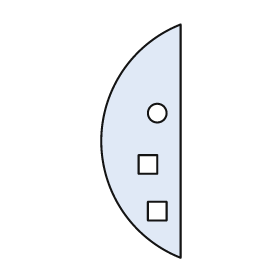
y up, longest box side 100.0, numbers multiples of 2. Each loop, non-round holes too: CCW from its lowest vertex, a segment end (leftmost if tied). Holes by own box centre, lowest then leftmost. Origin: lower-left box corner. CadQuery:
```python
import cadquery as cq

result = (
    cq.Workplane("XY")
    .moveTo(34.0, 0.0)
    .lineTo(34.0, 100.0)
    .threePointArc((0.0, 50.0), (34.0, 0.0))
    .close()
    .moveTo(20.0, 16.0)
    .lineTo(28.0, 16.0)
    .lineTo(28.0, 24.0)
    .lineTo(20.0, 24.0)
    .close()
    .moveTo(16.0, 36.0)
    .lineTo(24.0, 36.0)
    .lineTo(24.0, 44.0)
    .lineTo(16.0, 44.0)
    .close()
    .moveTo(24.0, 62.0)
    .circle(4.0)
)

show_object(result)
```